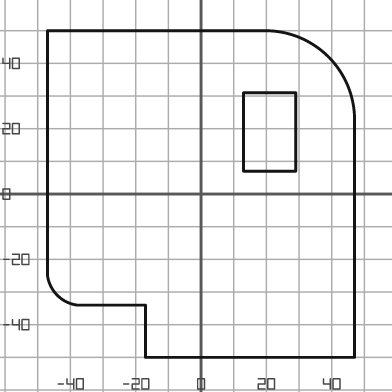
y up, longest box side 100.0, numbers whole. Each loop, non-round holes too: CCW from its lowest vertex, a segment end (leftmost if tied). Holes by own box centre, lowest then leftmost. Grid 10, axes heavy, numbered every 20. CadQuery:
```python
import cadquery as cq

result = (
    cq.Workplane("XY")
    .moveTo(-17.0, -50.0)
    .lineTo(47.0, -50.0)
    .lineTo(47.0, 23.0)
    .threePointArc((39.0, 42.0), (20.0, 50.0))
    .lineTo(-47.0, 50.0)
    .lineTo(-47.0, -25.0)
    .threePointArc((-44.0, -31.0), (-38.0, -34.0))
    .lineTo(-17.0, -34.0)
    .close()
    .moveTo(13.0, 7.0)
    .lineTo(29.0, 7.0)
    .lineTo(29.0, 31.0)
    .lineTo(13.0, 31.0)
    .close()
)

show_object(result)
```